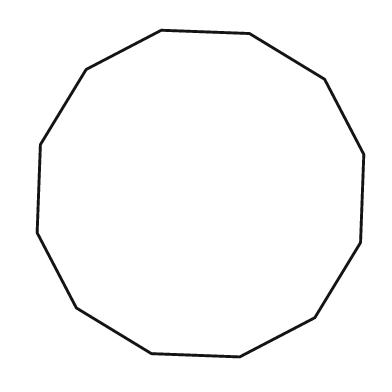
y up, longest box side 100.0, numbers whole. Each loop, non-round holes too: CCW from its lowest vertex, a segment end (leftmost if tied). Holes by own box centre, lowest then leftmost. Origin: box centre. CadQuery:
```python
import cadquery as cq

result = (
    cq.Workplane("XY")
    .moveTo(12.0, -50.0)
    .lineTo(35.0, -38.0)
    .lineTo(49.0, -15.0)
    .lineTo(50.0, 12.0)
    .lineTo(38.0, 35.0)
    .lineTo(15.0, 49.0)
    .lineTo(-12.0, 50.0)
    .lineTo(-35.0, 38.0)
    .lineTo(-49.0, 15.0)
    .lineTo(-50.0, -12.0)
    .lineTo(-38.0, -35.0)
    .lineTo(-15.0, -49.0)
    .close()
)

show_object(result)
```